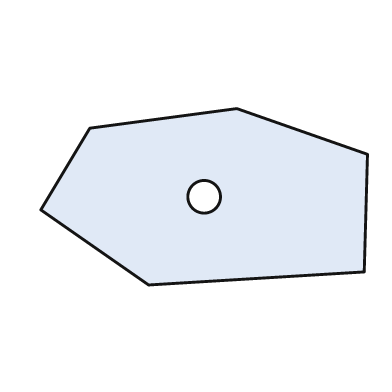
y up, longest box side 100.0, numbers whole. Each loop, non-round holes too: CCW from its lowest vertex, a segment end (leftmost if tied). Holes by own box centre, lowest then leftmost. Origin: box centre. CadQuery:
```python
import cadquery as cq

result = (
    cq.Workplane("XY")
    .moveTo(-17.0, -27.0)
    .lineTo(49.0, -23.0)
    .lineTo(50.0, 13.0)
    .lineTo(10.0, 27.0)
    .lineTo(-35.0, 21.0)
    .lineTo(-50.0, -4.0)
    .close()
    .moveTo(0.0, 0.0)
    .circle(5.0)
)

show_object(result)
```